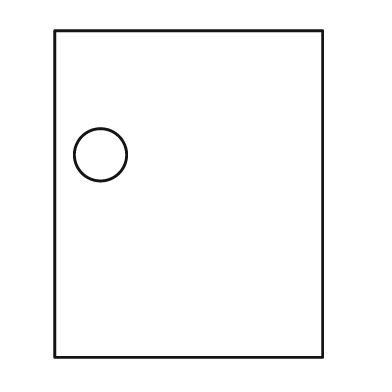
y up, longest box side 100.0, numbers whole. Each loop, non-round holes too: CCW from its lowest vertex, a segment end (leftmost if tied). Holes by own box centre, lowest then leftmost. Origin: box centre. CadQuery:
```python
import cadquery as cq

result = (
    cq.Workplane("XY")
    .moveTo(-41.0, -50.0)
    .lineTo(41.0, -50.0)
    .lineTo(41.0, 50.0)
    .lineTo(-41.0, 50.0)
    .close()
    .moveTo(-27.0, 12.0)
    .circle(8.0)
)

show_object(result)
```